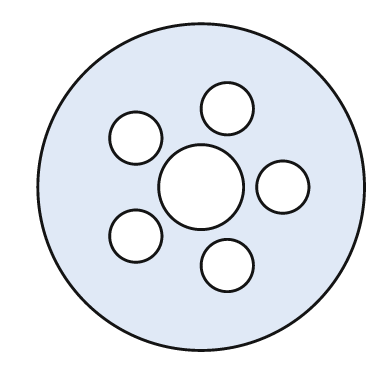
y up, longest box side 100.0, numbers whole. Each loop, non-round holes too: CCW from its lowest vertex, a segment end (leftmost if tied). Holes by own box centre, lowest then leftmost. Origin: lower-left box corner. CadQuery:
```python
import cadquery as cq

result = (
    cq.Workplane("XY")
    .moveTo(50.0, 50.0)
    .circle(50.0)
    .moveTo(58.0, 26.0)
    .circle(8.0)
    .moveTo(30.0, 35.0)
    .circle(8.0)
    .moveTo(50.0, 50.0)
    .circle(13.0)
    .moveTo(75.0, 50.0)
    .circle(8.0)
    .moveTo(30.0, 65.0)
    .circle(8.0)
    .moveTo(58.0, 74.0)
    .circle(8.0)
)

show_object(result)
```